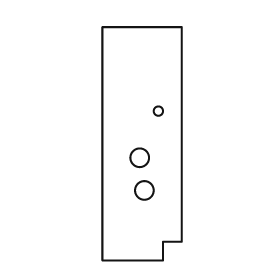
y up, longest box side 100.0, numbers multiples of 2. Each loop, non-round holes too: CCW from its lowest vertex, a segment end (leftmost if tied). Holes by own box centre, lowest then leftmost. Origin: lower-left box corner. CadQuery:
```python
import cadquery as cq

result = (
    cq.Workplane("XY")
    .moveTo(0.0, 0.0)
    .lineTo(26.0, 0.0)
    .lineTo(26.0, 8.0)
    .lineTo(34.0, 8.0)
    .lineTo(34.0, 100.0)
    .lineTo(0.0, 100.0)
    .close()
    .moveTo(18.0, 30.0)
    .circle(4.0)
    .moveTo(16.0, 44.0)
    .circle(4.0)
    .moveTo(24.0, 64.0)
    .circle(2.0)
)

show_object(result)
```